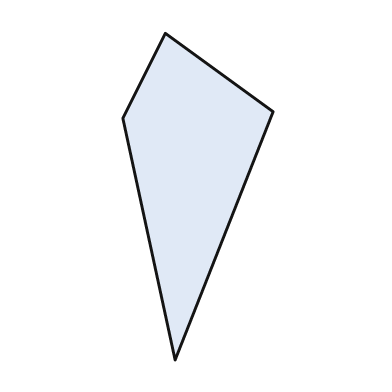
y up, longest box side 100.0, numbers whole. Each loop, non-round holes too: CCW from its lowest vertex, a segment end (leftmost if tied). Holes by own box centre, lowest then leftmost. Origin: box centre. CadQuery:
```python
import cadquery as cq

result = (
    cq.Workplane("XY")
    .moveTo(-7.0, -50.0)
    .lineTo(23.0, 26.0)
    .lineTo(-10.0, 50.0)
    .lineTo(-23.0, 24.0)
    .close()
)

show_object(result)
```